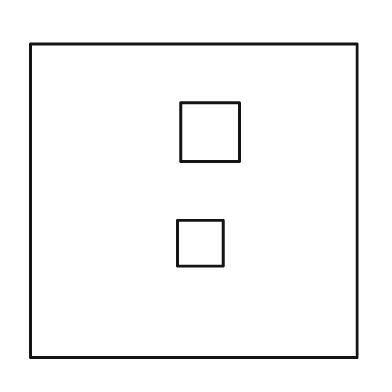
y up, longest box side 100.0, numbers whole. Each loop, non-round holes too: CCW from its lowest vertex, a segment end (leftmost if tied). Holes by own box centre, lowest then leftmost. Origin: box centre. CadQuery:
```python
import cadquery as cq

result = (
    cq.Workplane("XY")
    .moveTo(-50.0, -48.0)
    .lineTo(50.0, -48.0)
    .lineTo(50.0, 48.0)
    .lineTo(-50.0, 48.0)
    .close()
    .moveTo(-5.0, -20.0)
    .lineTo(9.0, -20.0)
    .lineTo(9.0, -6.0)
    .lineTo(-5.0, -6.0)
    .close()
    .moveTo(-4.0, 12.0)
    .lineTo(14.0, 12.0)
    .lineTo(14.0, 30.0)
    .lineTo(-4.0, 30.0)
    .close()
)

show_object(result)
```